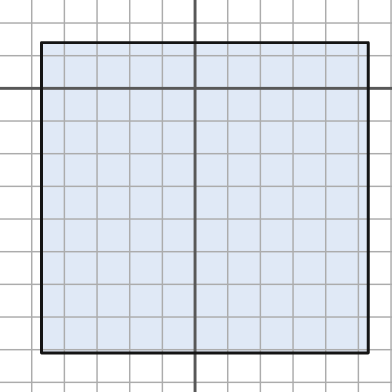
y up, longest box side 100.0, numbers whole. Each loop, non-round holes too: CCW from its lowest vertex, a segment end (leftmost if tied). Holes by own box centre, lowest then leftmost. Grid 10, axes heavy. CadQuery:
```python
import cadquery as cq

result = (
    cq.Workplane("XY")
    .moveTo(-47.0, -81.0)
    .lineTo(53.0, -81.0)
    .lineTo(53.0, 14.0)
    .lineTo(-47.0, 14.0)
    .close()
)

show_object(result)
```